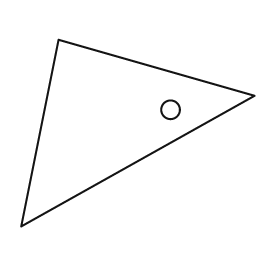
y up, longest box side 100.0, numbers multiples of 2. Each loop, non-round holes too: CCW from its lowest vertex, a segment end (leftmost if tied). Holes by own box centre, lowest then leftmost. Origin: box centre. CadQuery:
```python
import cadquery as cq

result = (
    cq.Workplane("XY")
    .moveTo(-50.0, -40.0)
    .lineTo(50.0, 16.0)
    .lineTo(-34.0, 40.0)
    .close()
    .moveTo(14.0, 10.0)
    .circle(4.0)
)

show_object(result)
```